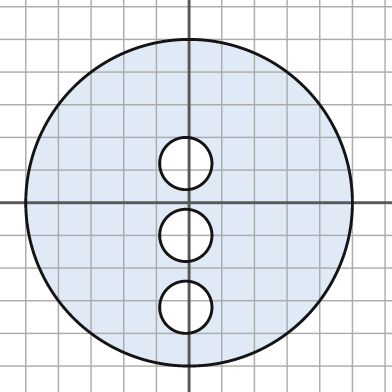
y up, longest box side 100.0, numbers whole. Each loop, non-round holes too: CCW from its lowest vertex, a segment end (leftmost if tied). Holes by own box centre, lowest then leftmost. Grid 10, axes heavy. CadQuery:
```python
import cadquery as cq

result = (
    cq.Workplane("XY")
    .moveTo(0.0, 0.0)
    .circle(50.0)
    .moveTo(-1.0, -32.0)
    .circle(8.0)
    .moveTo(-1.0, -10.0)
    .circle(8.0)
    .moveTo(-1.0, 12.0)
    .circle(8.0)
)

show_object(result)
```